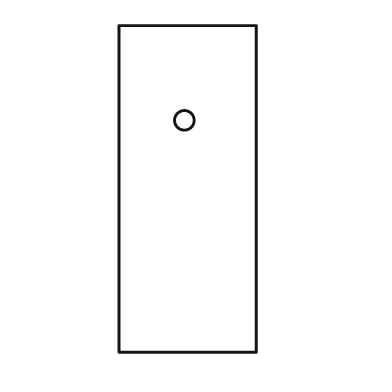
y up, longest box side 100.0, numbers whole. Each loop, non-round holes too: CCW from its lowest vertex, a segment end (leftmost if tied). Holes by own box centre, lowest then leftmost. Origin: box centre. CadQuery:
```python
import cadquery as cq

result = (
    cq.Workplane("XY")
    .moveTo(-21.0, -50.0)
    .lineTo(21.0, -50.0)
    .lineTo(21.0, 50.0)
    .lineTo(-21.0, 50.0)
    .close()
    .moveTo(-1.0, 21.0)
    .circle(3.0)
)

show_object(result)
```